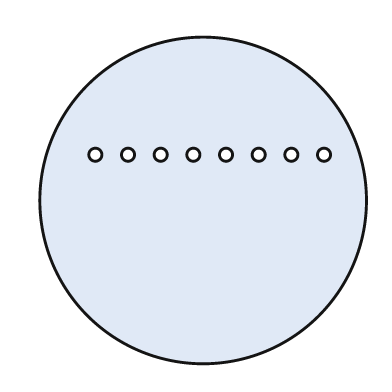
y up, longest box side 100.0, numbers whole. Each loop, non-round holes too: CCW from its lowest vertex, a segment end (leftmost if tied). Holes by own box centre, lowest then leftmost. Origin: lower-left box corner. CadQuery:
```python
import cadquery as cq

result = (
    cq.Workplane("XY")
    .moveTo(50.0, 50.0)
    .circle(50.0)
    .moveTo(17.0, 64.0)
    .circle(2.0)
    .moveTo(27.0, 64.0)
    .circle(2.0)
    .moveTo(37.0, 64.0)
    .circle(2.0)
    .moveTo(47.0, 64.0)
    .circle(2.0)
    .moveTo(57.0, 64.0)
    .circle(2.0)
    .moveTo(67.0, 64.0)
    .circle(2.0)
    .moveTo(77.0, 64.0)
    .circle(2.0)
    .moveTo(87.0, 64.0)
    .circle(2.0)
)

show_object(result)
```